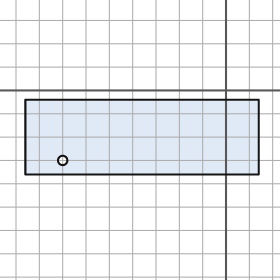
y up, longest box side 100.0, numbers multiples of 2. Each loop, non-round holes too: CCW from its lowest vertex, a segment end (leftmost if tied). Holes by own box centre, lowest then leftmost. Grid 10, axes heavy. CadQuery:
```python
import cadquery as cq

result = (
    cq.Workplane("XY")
    .moveTo(-86.0, -36.0)
    .lineTo(14.0, -36.0)
    .lineTo(14.0, -4.0)
    .lineTo(-86.0, -4.0)
    .close()
    .moveTo(-70.0, -30.0)
    .circle(2.0)
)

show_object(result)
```